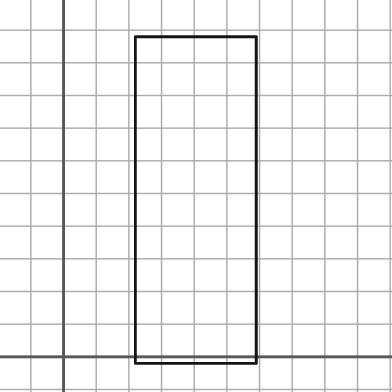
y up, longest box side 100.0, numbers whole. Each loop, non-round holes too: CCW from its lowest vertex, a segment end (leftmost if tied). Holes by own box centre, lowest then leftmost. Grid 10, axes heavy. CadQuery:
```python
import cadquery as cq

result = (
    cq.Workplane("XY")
    .moveTo(22.0, -2.0)
    .lineTo(59.0, -2.0)
    .lineTo(59.0, 98.0)
    .lineTo(22.0, 98.0)
    .close()
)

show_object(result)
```